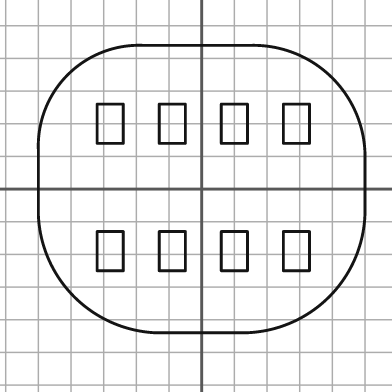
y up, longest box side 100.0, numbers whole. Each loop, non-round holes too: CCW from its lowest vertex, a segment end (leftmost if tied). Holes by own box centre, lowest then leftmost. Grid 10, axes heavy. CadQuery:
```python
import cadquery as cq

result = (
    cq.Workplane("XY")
    .moveTo(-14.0, -44.0)
    .lineTo(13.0, -44.0)
    .threePointArc((39.0, -33.0), (50.0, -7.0))
    .lineTo(50.0, 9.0)
    .threePointArc((40.0, 34.0), (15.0, 44.0))
    .lineTo(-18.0, 44.0)
    .threePointArc((-41.0, 35.0), (-50.0, 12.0))
    .lineTo(-50.0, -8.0)
    .threePointArc((-39.0, -33.0), (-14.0, -44.0))
    .close()
    .moveTo(-32.0, -25.0)
    .lineTo(-24.0, -25.0)
    .lineTo(-24.0, -13.0)
    .lineTo(-32.0, -13.0)
    .close()
    .moveTo(-13.0, -25.0)
    .lineTo(-5.0, -25.0)
    .lineTo(-5.0, -13.0)
    .lineTo(-13.0, -13.0)
    .close()
    .moveTo(6.0, -25.0)
    .lineTo(14.0, -25.0)
    .lineTo(14.0, -13.0)
    .lineTo(6.0, -13.0)
    .close()
    .moveTo(25.0, -25.0)
    .lineTo(33.0, -25.0)
    .lineTo(33.0, -13.0)
    .lineTo(25.0, -13.0)
    .close()
    .moveTo(-32.0, 14.0)
    .lineTo(-24.0, 14.0)
    .lineTo(-24.0, 26.0)
    .lineTo(-32.0, 26.0)
    .close()
    .moveTo(-13.0, 14.0)
    .lineTo(-5.0, 14.0)
    .lineTo(-5.0, 26.0)
    .lineTo(-13.0, 26.0)
    .close()
    .moveTo(6.0, 14.0)
    .lineTo(14.0, 14.0)
    .lineTo(14.0, 26.0)
    .lineTo(6.0, 26.0)
    .close()
    .moveTo(25.0, 14.0)
    .lineTo(33.0, 14.0)
    .lineTo(33.0, 26.0)
    .lineTo(25.0, 26.0)
    .close()
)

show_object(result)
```